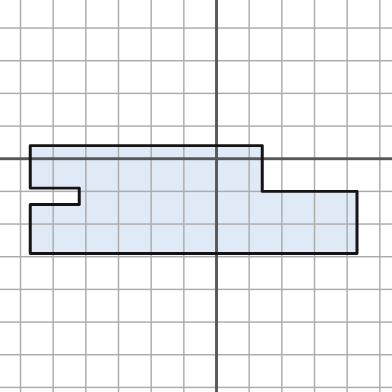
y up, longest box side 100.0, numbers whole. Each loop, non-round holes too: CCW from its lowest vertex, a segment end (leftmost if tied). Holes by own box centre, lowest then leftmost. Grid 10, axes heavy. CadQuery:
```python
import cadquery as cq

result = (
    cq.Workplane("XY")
    .moveTo(-57.0, -29.0)
    .lineTo(43.0, -29.0)
    .lineTo(43.0, -10.0)
    .lineTo(14.0, -10.0)
    .lineTo(14.0, 4.0)
    .lineTo(-57.0, 4.0)
    .lineTo(-57.0, -9.0)
    .lineTo(-42.0, -9.0)
    .lineTo(-42.0, -14.0)
    .lineTo(-57.0, -14.0)
    .close()
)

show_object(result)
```